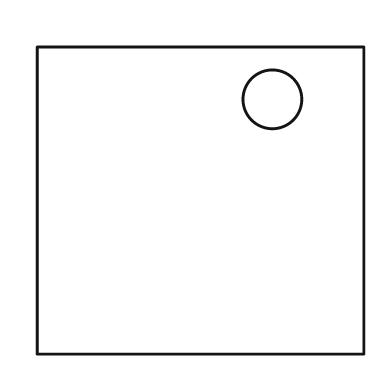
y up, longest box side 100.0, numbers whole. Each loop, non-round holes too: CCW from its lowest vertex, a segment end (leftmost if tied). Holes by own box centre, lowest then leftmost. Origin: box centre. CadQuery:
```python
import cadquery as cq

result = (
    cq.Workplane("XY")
    .moveTo(-50.0, -47.0)
    .lineTo(50.0, -47.0)
    .lineTo(50.0, 47.0)
    .lineTo(-50.0, 47.0)
    .close()
    .moveTo(22.0, 31.0)
    .circle(9.0)
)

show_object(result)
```